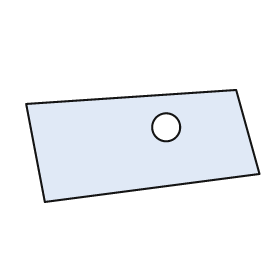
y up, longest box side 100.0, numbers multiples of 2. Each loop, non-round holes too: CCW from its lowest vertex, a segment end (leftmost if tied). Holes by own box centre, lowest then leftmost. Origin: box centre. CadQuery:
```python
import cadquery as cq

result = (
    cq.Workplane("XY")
    .moveTo(-42.0, -24.0)
    .lineTo(50.0, -12.0)
    .lineTo(40.0, 24.0)
    .lineTo(-50.0, 18.0)
    .close()
    .moveTo(10.0, 8.0)
    .circle(6.0)
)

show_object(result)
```